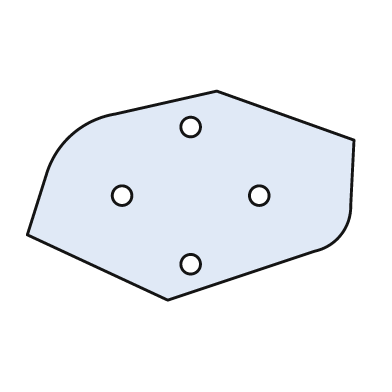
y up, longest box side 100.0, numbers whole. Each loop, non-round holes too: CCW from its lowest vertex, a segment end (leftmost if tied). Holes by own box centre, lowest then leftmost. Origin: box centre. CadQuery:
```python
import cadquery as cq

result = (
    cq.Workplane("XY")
    .moveTo(-7.0, -32.0)
    .lineTo(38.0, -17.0)
    .threePointArc((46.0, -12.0), (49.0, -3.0))
    .lineTo(50.0, 17.0)
    .lineTo(8.0, 32.0)
    .lineTo(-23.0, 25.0)
    .threePointArc((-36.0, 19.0), (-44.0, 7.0))
    .lineTo(-50.0, -12.0)
    .close()
    .moveTo(0.0, -21.0)
    .circle(3.0)
    .moveTo(-21.0, 0.0)
    .circle(3.0)
    .moveTo(21.0, 0.0)
    .circle(3.0)
    .moveTo(0.0, 21.0)
    .circle(3.0)
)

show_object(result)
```